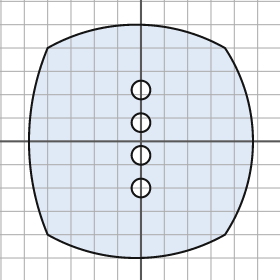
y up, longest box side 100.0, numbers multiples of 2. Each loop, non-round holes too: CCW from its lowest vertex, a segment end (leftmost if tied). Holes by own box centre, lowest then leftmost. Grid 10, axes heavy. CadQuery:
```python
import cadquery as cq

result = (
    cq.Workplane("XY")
    .moveTo(-40.0, -40.0)
    .threePointArc((-2.0, -50.0), (36.0, -40.0))
    .threePointArc((48.0, 0.0), (36.0, 40.0))
    .threePointArc((-2.0, 50.0), (-40.0, 40.0))
    .threePointArc((-48.0, 0.0), (-40.0, -40.0))
    .close()
    .moveTo(0.0, -20.0)
    .circle(4.0)
    .moveTo(0.0, -6.0)
    .circle(4.0)
    .moveTo(0.0, 8.0)
    .circle(4.0)
    .moveTo(0.0, 22.0)
    .circle(4.0)
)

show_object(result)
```